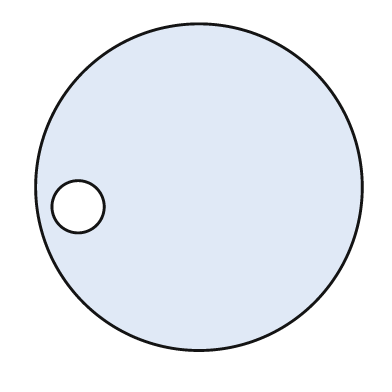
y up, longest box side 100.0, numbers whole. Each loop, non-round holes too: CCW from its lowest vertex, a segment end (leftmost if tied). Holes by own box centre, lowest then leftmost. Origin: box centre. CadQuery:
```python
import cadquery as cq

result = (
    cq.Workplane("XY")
    .moveTo(0.0, 0.0)
    .circle(50.0)
    .moveTo(-37.0, -6.0)
    .circle(8.0)
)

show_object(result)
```